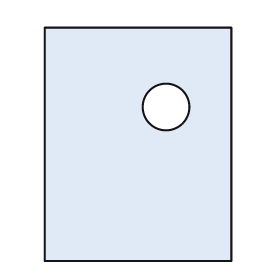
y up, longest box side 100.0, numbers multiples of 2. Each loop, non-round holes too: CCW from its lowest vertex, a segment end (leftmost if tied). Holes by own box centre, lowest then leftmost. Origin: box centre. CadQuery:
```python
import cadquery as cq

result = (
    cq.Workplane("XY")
    .moveTo(-40.0, -50.0)
    .lineTo(40.0, -50.0)
    .lineTo(40.0, 50.0)
    .lineTo(-40.0, 50.0)
    .close()
    .moveTo(12.0, 16.0)
    .circle(10.0)
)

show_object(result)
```